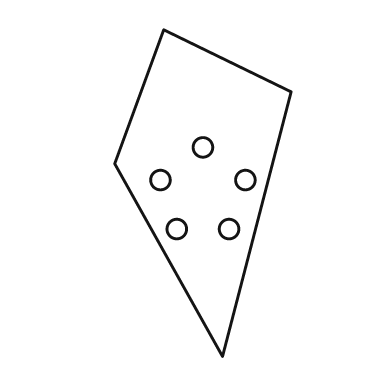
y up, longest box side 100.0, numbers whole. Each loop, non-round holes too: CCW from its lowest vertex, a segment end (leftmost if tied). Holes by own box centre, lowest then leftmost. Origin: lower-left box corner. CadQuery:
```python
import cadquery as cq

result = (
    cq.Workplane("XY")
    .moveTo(33.0, 0.0)
    .lineTo(54.0, 81.0)
    .lineTo(15.0, 100.0)
    .lineTo(0.0, 59.0)
    .close()
    .moveTo(19.0, 39.0)
    .circle(3.0)
    .moveTo(35.0, 39.0)
    .circle(3.0)
    .moveTo(14.0, 54.0)
    .circle(3.0)
    .moveTo(40.0, 54.0)
    .circle(3.0)
    .moveTo(27.0, 64.0)
    .circle(3.0)
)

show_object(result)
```